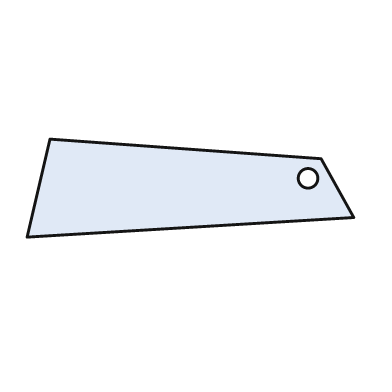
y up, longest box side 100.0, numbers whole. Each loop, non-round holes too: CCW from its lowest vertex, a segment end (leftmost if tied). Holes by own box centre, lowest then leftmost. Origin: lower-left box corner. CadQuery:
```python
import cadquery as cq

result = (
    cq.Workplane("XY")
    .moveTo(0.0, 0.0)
    .lineTo(100.0, 6.0)
    .lineTo(90.0, 24.0)
    .lineTo(7.0, 30.0)
    .close()
    .moveTo(86.0, 18.0)
    .circle(3.0)
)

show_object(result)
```